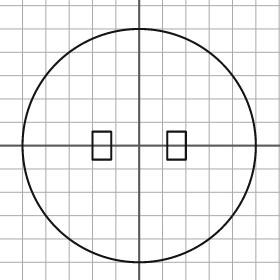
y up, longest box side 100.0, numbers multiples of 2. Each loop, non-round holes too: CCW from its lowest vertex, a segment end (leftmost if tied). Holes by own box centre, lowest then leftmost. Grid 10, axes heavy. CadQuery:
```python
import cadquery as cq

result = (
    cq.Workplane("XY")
    .moveTo(0.0, 0.0)
    .circle(50.0)
    .moveTo(-20.0, -6.0)
    .lineTo(-12.0, -6.0)
    .lineTo(-12.0, 6.0)
    .lineTo(-20.0, 6.0)
    .close()
    .moveTo(12.0, -6.0)
    .lineTo(20.0, -6.0)
    .lineTo(20.0, 6.0)
    .lineTo(12.0, 6.0)
    .close()
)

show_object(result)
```